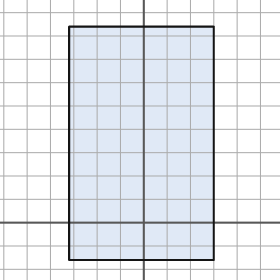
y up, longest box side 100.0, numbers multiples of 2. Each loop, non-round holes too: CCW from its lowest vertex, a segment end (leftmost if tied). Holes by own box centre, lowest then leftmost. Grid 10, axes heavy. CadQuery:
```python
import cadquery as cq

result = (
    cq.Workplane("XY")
    .moveTo(-32.0, -16.0)
    .lineTo(30.0, -16.0)
    .lineTo(30.0, 84.0)
    .lineTo(-32.0, 84.0)
    .close()
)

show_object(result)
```